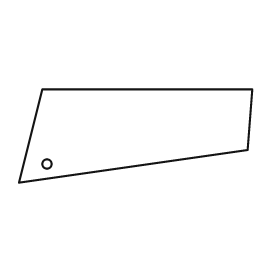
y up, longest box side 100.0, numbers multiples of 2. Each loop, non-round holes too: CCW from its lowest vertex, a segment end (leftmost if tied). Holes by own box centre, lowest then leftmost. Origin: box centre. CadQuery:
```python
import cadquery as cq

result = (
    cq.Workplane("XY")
    .moveTo(-50.0, -20.0)
    .lineTo(48.0, -6.0)
    .lineTo(50.0, 20.0)
    .lineTo(-40.0, 20.0)
    .close()
    .moveTo(-38.0, -12.0)
    .circle(2.0)
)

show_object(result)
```